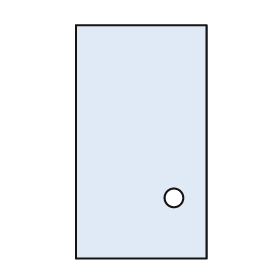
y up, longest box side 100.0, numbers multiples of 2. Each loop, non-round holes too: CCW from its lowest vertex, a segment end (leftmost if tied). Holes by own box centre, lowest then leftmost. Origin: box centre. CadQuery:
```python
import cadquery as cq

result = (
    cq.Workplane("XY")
    .moveTo(-28.0, -50.0)
    .lineTo(28.0, -50.0)
    .lineTo(28.0, 50.0)
    .lineTo(-28.0, 50.0)
    .close()
    .moveTo(14.0, -24.0)
    .circle(4.0)
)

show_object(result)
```